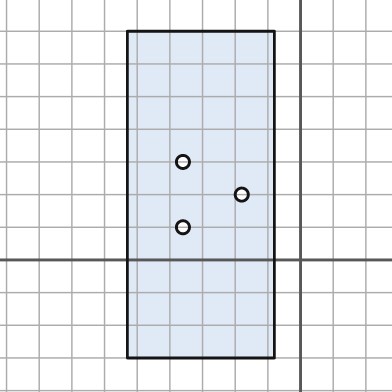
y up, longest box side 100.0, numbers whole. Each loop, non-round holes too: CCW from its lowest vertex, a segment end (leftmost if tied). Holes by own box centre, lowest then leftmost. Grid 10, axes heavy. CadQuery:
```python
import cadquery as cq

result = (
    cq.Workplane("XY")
    .moveTo(-53.0, -30.0)
    .lineTo(-8.0, -30.0)
    .lineTo(-8.0, 70.0)
    .lineTo(-53.0, 70.0)
    .close()
    .moveTo(-36.0, 10.0)
    .circle(2.0)
    .moveTo(-18.0, 20.0)
    .circle(2.0)
    .moveTo(-36.0, 30.0)
    .circle(2.0)
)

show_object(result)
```